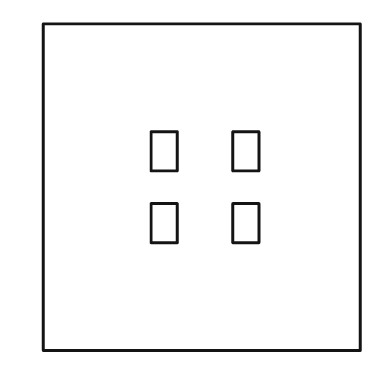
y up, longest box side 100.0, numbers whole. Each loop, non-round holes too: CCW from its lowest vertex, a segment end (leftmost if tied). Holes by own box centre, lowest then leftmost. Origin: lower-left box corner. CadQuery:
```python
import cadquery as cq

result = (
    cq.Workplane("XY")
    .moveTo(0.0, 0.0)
    .lineTo(97.0, 0.0)
    .lineTo(97.0, 100.0)
    .lineTo(0.0, 100.0)
    .close()
    .moveTo(33.0, 33.0)
    .lineTo(41.0, 33.0)
    .lineTo(41.0, 45.0)
    .lineTo(33.0, 45.0)
    .close()
    .moveTo(58.0, 33.0)
    .lineTo(66.0, 33.0)
    .lineTo(66.0, 45.0)
    .lineTo(58.0, 45.0)
    .close()
    .moveTo(33.0, 55.0)
    .lineTo(41.0, 55.0)
    .lineTo(41.0, 67.0)
    .lineTo(33.0, 67.0)
    .close()
    .moveTo(58.0, 55.0)
    .lineTo(66.0, 55.0)
    .lineTo(66.0, 67.0)
    .lineTo(58.0, 67.0)
    .close()
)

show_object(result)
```